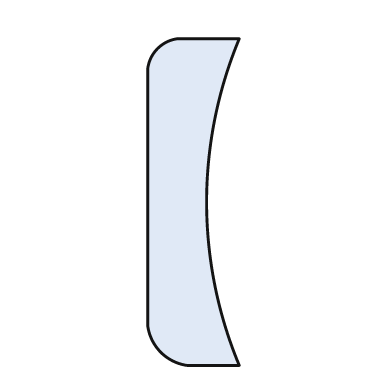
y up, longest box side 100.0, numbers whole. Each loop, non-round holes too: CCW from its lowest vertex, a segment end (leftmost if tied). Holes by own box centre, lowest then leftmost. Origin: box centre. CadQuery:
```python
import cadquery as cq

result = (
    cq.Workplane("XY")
    .moveTo(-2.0, -50.0)
    .lineTo(14.0, -50.0)
    .threePointArc((4.0, 0.0), (14.0, 50.0))
    .lineTo(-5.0, 50.0)
    .threePointArc((-11.0, 47.0), (-14.0, 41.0))
    .lineTo(-14.0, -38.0)
    .threePointArc((-10.0, -46.0), (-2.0, -50.0))
    .close()
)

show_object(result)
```